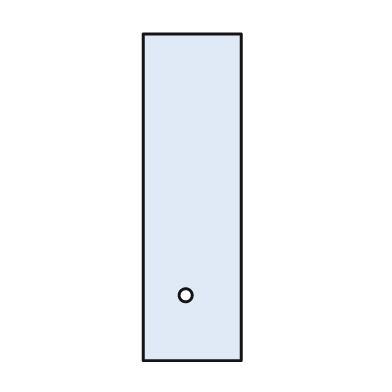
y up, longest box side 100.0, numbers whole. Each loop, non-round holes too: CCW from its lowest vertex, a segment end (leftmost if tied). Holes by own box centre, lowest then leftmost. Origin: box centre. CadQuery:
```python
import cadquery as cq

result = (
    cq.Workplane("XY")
    .moveTo(-15.0, -50.0)
    .lineTo(15.0, -50.0)
    .lineTo(15.0, 50.0)
    .lineTo(-15.0, 50.0)
    .close()
    .moveTo(-2.0, -30.0)
    .circle(2.0)
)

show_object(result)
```